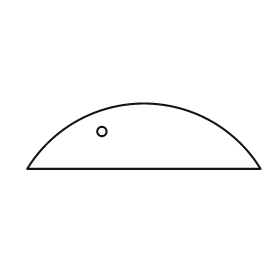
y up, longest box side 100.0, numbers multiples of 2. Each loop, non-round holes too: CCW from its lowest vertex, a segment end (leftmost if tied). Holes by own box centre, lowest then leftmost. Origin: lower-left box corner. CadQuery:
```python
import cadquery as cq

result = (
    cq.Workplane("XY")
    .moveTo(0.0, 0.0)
    .lineTo(100.0, 0.0)
    .threePointArc((50.0, 28.0), (0.0, 0.0))
    .close()
    .moveTo(32.0, 16.0)
    .circle(2.0)
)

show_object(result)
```